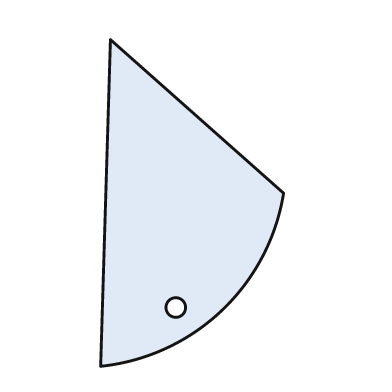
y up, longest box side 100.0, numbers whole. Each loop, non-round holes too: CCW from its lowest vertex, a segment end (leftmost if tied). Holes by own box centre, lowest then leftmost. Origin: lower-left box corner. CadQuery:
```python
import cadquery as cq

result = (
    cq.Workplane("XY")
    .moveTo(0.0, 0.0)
    .threePointArc((37.0, 17.0), (56.0, 53.0))
    .lineTo(3.0, 100.0)
    .close()
    .moveTo(23.0, 18.0)
    .circle(3.0)
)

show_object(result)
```